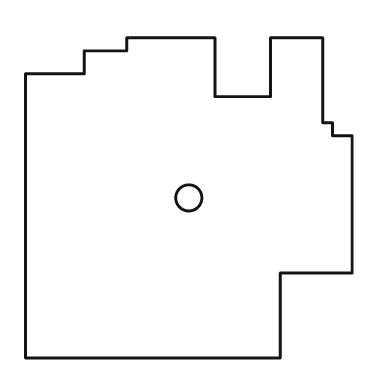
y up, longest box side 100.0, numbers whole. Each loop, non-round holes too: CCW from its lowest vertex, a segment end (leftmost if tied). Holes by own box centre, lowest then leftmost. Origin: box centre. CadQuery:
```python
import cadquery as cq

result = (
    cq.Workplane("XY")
    .moveTo(-50.0, -49.0)
    .lineTo(28.0, -49.0)
    .lineTo(28.0, -23.0)
    .lineTo(50.0, -23.0)
    .lineTo(50.0, 19.0)
    .lineTo(44.0, 19.0)
    .lineTo(44.0, 23.0)
    .lineTo(41.0, 23.0)
    .lineTo(41.0, 49.0)
    .lineTo(25.0, 49.0)
    .lineTo(25.0, 31.0)
    .lineTo(8.0, 31.0)
    .lineTo(8.0, 49.0)
    .lineTo(-19.0, 49.0)
    .lineTo(-19.0, 45.0)
    .lineTo(-32.0, 45.0)
    .lineTo(-32.0, 38.0)
    .lineTo(-50.0, 38.0)
    .close()
    .moveTo(0.0, 0.0)
    .circle(4.0)
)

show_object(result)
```